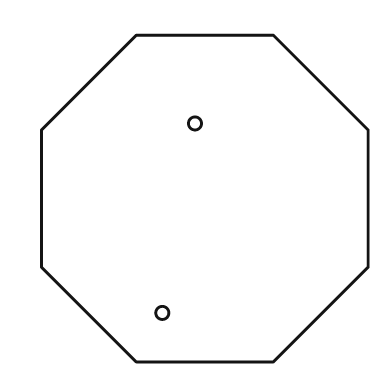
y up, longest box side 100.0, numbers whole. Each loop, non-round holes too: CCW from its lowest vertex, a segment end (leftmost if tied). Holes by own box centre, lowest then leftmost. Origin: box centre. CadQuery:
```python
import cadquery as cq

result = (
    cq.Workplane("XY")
    .moveTo(-21.0, -50.0)
    .lineTo(21.0, -50.0)
    .lineTo(50.0, -21.0)
    .lineTo(50.0, 21.0)
    .lineTo(21.0, 50.0)
    .lineTo(-21.0, 50.0)
    .lineTo(-50.0, 21.0)
    .lineTo(-50.0, -21.0)
    .close()
    .moveTo(-13.0, -35.0)
    .circle(2.0)
    .moveTo(-3.0, 23.0)
    .circle(2.0)
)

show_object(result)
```